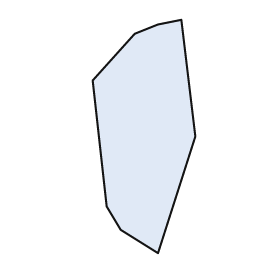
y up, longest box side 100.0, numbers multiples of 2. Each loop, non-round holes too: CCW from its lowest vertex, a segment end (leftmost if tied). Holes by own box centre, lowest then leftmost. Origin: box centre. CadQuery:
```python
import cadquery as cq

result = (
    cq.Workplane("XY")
    .moveTo(6.0, -50.0)
    .lineTo(22.0, 0.0)
    .lineTo(16.0, 50.0)
    .lineTo(6.0, 48.0)
    .lineTo(-4.0, 44.0)
    .lineTo(-22.0, 24.0)
    .lineTo(-16.0, -30.0)
    .lineTo(-10.0, -40.0)
    .close()
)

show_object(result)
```